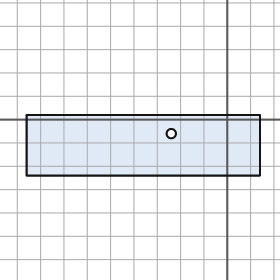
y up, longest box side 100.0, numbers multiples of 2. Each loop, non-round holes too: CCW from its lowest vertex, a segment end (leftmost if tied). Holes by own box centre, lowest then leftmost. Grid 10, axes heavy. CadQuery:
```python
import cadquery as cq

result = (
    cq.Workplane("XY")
    .moveTo(-86.0, -24.0)
    .lineTo(14.0, -24.0)
    .lineTo(14.0, 2.0)
    .lineTo(-86.0, 2.0)
    .close()
    .moveTo(-24.0, -6.0)
    .circle(2.0)
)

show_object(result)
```